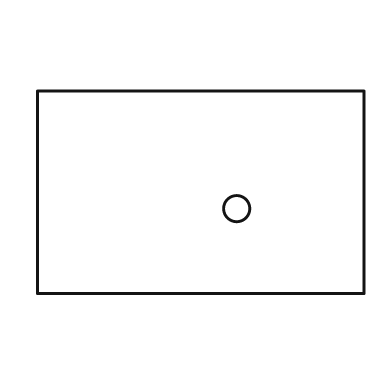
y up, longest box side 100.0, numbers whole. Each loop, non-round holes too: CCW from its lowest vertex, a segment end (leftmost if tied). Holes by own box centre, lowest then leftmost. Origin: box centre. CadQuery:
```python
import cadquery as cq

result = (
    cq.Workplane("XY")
    .moveTo(-50.0, -31.0)
    .lineTo(50.0, -31.0)
    .lineTo(50.0, 31.0)
    .lineTo(-50.0, 31.0)
    .close()
    .moveTo(11.0, -5.0)
    .circle(4.0)
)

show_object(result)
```